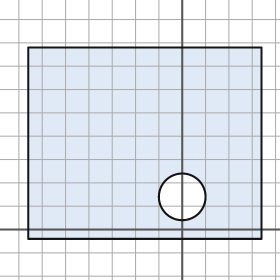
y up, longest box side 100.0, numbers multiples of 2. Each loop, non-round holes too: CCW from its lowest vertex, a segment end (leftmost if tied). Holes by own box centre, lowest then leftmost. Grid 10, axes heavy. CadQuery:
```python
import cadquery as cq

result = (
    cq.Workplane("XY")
    .moveTo(-66.0, -4.0)
    .lineTo(34.0, -4.0)
    .lineTo(34.0, 78.0)
    .lineTo(-66.0, 78.0)
    .close()
    .moveTo(0.0, 14.0)
    .circle(10.0)
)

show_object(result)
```